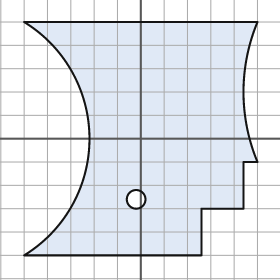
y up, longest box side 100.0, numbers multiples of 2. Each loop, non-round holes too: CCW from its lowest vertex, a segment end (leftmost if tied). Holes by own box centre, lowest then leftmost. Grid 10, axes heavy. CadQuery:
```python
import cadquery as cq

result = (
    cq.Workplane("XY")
    .moveTo(-50.0, -50.0)
    .lineTo(26.0, -50.0)
    .lineTo(26.0, -30.0)
    .lineTo(44.0, -30.0)
    .lineTo(44.0, -10.0)
    .lineTo(50.0, -10.0)
    .threePointArc((44.0, 20.0), (50.0, 50.0))
    .lineTo(-50.0, 50.0)
    .threePointArc((-22.0, 0.0), (-50.0, -50.0))
    .close()
    .moveTo(-2.0, -26.0)
    .circle(4.0)
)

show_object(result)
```